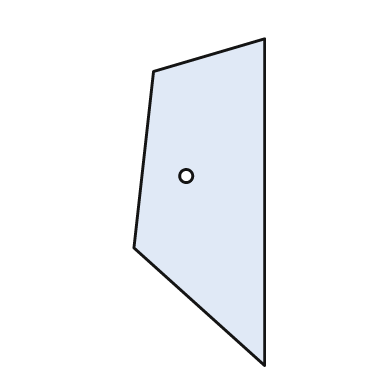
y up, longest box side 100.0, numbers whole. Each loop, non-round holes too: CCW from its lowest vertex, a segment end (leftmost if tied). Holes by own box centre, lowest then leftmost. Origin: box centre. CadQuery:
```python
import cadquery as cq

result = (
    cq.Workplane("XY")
    .moveTo(20.0, -50.0)
    .lineTo(20.0, 50.0)
    .lineTo(-14.0, 40.0)
    .lineTo(-20.0, -14.0)
    .close()
    .moveTo(-4.0, 8.0)
    .circle(2.0)
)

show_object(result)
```